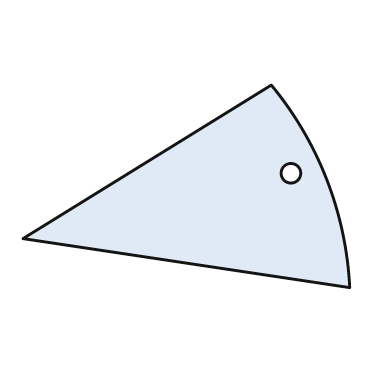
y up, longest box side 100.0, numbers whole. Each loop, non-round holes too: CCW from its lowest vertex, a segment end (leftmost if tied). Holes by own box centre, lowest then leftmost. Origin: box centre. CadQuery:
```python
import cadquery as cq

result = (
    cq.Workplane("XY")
    .moveTo(50.0, -31.0)
    .threePointArc((43.0, 2.0), (26.0, 31.0))
    .lineTo(-50.0, -16.0)
    .close()
    .moveTo(32.0, 4.0)
    .circle(3.0)
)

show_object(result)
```